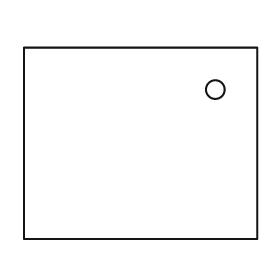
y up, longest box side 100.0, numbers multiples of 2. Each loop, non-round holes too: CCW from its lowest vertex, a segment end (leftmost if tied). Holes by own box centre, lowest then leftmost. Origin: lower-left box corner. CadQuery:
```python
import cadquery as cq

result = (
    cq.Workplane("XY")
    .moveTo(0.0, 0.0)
    .lineTo(100.0, 0.0)
    .lineTo(100.0, 82.0)
    .lineTo(0.0, 82.0)
    .close()
    .moveTo(82.0, 64.0)
    .circle(4.0)
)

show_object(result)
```